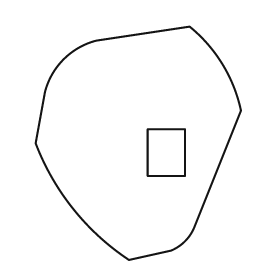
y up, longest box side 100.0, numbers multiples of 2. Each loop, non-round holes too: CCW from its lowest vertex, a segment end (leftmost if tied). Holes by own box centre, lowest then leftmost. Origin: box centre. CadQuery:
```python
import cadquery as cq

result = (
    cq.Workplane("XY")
    .moveTo(-4.0, -50.0)
    .lineTo(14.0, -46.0)
    .threePointArc((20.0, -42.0), (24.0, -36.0))
    .lineTo(44.0, 14.0)
    .threePointArc((36.0, 34.0), (22.0, 50.0))
    .lineTo(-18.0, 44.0)
    .threePointArc((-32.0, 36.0), (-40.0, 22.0))
    .lineTo(-44.0, 0.0)
    .threePointArc((-28.0, -28.0), (-4.0, -50.0))
    .close()
    .moveTo(4.0, -14.0)
    .lineTo(20.0, -14.0)
    .lineTo(20.0, 6.0)
    .lineTo(4.0, 6.0)
    .close()
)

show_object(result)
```